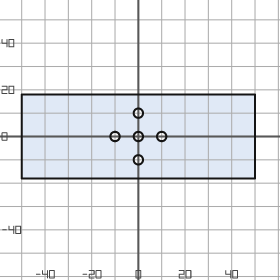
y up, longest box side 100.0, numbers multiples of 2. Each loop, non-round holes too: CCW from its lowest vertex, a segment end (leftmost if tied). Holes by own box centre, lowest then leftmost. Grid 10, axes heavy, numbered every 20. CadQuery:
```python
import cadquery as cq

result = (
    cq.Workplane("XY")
    .moveTo(-50.0, -18.0)
    .lineTo(50.0, -18.0)
    .lineTo(50.0, 18.0)
    .lineTo(-50.0, 18.0)
    .close()
    .moveTo(0.0, -10.0)
    .circle(2.0)
    .moveTo(-10.0, 0.0)
    .circle(2.0)
    .moveTo(0.0, 0.0)
    .circle(2.0)
    .moveTo(10.0, 0.0)
    .circle(2.0)
    .moveTo(0.0, 10.0)
    .circle(2.0)
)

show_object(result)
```